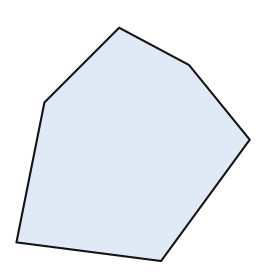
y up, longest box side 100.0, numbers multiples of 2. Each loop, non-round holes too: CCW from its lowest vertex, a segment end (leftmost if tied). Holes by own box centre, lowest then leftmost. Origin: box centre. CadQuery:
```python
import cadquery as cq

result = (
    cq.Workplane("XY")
    .moveTo(12.0, -50.0)
    .lineTo(50.0, 2.0)
    .lineTo(24.0, 34.0)
    .lineTo(-6.0, 50.0)
    .lineTo(-38.0, 18.0)
    .lineTo(-50.0, -42.0)
    .close()
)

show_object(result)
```